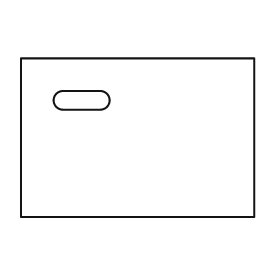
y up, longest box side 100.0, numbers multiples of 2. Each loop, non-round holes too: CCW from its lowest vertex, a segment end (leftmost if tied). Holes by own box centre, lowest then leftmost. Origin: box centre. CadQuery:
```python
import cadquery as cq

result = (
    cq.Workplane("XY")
    .moveTo(-50.0, -34.0)
    .lineTo(50.0, -34.0)
    .lineTo(50.0, 34.0)
    .lineTo(-50.0, 34.0)
    .close()
    .moveTo(-32.0, 12.0)
    .lineTo(-16.0, 12.0)
    .threePointArc((-12.0, 16.0), (-16.0, 20.0))
    .lineTo(-32.0, 20.0)
    .threePointArc((-36.0, 16.0), (-32.0, 12.0))
    .close()
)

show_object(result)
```